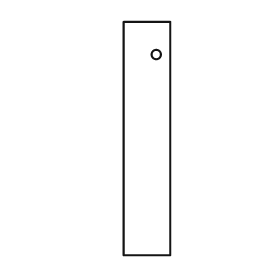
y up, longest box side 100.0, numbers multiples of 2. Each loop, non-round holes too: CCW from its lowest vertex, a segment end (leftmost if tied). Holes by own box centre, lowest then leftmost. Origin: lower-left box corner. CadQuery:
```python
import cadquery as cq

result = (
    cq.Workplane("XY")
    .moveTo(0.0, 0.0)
    .lineTo(20.0, 0.0)
    .lineTo(20.0, 100.0)
    .lineTo(0.0, 100.0)
    .close()
    .moveTo(14.0, 86.0)
    .circle(2.0)
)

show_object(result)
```